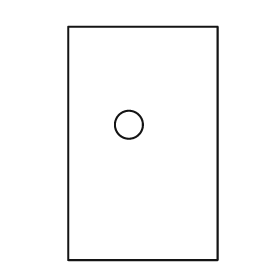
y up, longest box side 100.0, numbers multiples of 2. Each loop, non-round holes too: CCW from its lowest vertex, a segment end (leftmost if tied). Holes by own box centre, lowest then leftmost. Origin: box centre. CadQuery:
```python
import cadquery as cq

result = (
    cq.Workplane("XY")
    .moveTo(-32.0, -50.0)
    .lineTo(32.0, -50.0)
    .lineTo(32.0, 50.0)
    .lineTo(-32.0, 50.0)
    .close()
    .moveTo(-6.0, 8.0)
    .circle(6.0)
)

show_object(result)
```